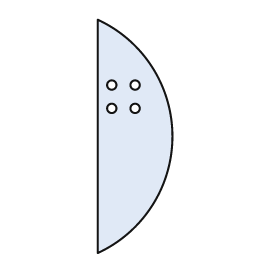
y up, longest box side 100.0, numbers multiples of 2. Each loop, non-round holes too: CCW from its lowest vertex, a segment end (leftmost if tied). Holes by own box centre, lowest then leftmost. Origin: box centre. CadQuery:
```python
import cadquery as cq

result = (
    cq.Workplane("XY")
    .moveTo(-16.0, -50.0)
    .threePointArc((16.0, 0.0), (-16.0, 50.0))
    .close()
    .moveTo(-10.0, 12.0)
    .circle(2.0)
    .moveTo(0.0, 12.0)
    .circle(2.0)
    .moveTo(-10.0, 22.0)
    .circle(2.0)
    .moveTo(0.0, 22.0)
    .circle(2.0)
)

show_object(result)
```